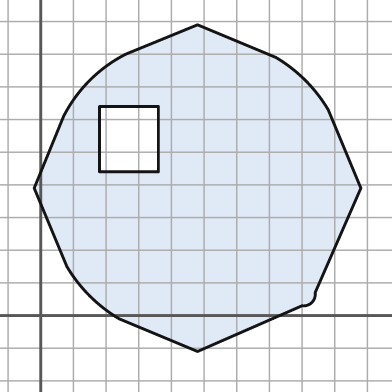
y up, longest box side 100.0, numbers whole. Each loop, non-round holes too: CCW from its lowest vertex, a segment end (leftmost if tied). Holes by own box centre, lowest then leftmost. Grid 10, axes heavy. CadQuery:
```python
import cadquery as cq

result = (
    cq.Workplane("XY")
    .moveTo(48.0, -11.0)
    .lineTo(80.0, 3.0)
    .threePointArc((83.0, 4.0), (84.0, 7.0))
    .lineTo(98.0, 39.0)
    .lineTo(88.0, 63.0)
    .threePointArc((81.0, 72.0), (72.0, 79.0))
    .lineTo(48.0, 89.0)
    .lineTo(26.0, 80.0)
    .threePointArc((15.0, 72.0), (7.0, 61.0))
    .lineTo(-2.0, 39.0)
    .lineTo(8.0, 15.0)
    .threePointArc((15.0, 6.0), (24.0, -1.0))
    .close()
    .moveTo(18.0, 44.0)
    .lineTo(36.0, 44.0)
    .lineTo(36.0, 64.0)
    .lineTo(18.0, 64.0)
    .close()
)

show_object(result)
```